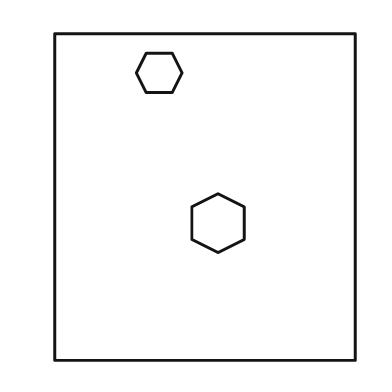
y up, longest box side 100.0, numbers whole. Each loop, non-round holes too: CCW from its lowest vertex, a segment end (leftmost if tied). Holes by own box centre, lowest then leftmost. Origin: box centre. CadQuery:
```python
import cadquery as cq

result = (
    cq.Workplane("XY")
    .moveTo(-46.0, -50.0)
    .lineTo(46.0, -50.0)
    .lineTo(46.0, 50.0)
    .lineTo(-46.0, 50.0)
    .close()
    .moveTo(4.0, -17.0)
    .lineTo(12.0, -13.0)
    .lineTo(12.0, -3.0)
    .lineTo(4.0, 1.0)
    .lineTo(-4.0, -3.0)
    .lineTo(-4.0, -13.0)
    .close()
    .moveTo(-18.0, 32.0)
    .lineTo(-10.0, 32.0)
    .lineTo(-7.0, 38.0)
    .lineTo(-10.0, 44.0)
    .lineTo(-18.0, 44.0)
    .lineTo(-21.0, 38.0)
    .close()
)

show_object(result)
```